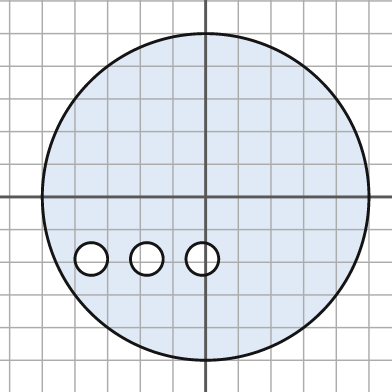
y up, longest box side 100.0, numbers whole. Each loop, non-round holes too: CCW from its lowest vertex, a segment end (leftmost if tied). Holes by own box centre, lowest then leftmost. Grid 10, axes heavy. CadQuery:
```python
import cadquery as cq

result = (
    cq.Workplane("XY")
    .moveTo(0.0, 0.0)
    .circle(50.0)
    .moveTo(-35.0, -19.0)
    .circle(5.0)
    .moveTo(-18.0, -19.0)
    .circle(5.0)
    .moveTo(-1.0, -19.0)
    .circle(5.0)
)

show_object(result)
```